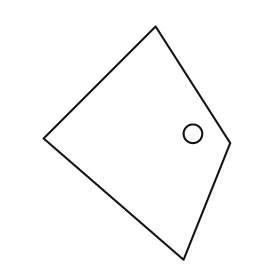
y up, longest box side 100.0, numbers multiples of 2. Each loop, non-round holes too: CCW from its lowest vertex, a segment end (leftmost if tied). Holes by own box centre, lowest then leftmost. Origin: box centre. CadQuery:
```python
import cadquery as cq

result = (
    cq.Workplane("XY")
    .moveTo(20.0, -50.0)
    .lineTo(40.0, 0.0)
    .lineTo(8.0, 50.0)
    .lineTo(-40.0, 2.0)
    .close()
    .moveTo(24.0, 4.0)
    .circle(4.0)
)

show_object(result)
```